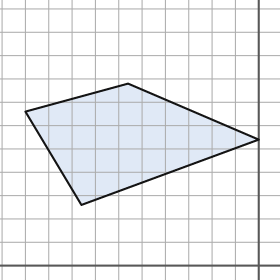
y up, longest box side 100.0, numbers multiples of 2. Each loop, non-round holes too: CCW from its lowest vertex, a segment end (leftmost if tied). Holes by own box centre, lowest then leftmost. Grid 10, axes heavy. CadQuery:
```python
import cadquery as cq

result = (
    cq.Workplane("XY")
    .moveTo(-76.0, 26.0)
    .lineTo(0.0, 54.0)
    .lineTo(-56.0, 78.0)
    .lineTo(-100.0, 66.0)
    .close()
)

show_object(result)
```